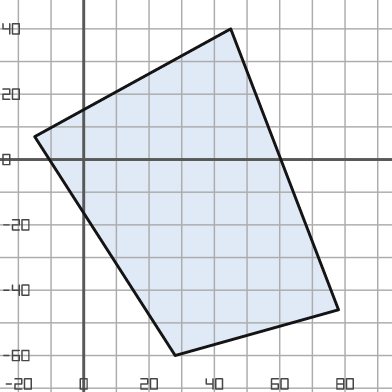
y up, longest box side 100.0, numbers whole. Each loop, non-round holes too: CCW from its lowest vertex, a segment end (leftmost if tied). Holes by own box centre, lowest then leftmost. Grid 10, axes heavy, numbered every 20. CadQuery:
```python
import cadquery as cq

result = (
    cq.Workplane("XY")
    .moveTo(28.0, -60.0)
    .lineTo(78.0, -46.0)
    .lineTo(45.0, 40.0)
    .lineTo(-15.0, 7.0)
    .close()
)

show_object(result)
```